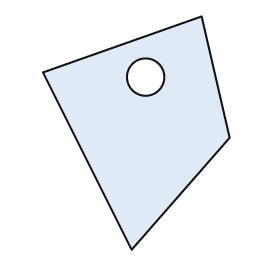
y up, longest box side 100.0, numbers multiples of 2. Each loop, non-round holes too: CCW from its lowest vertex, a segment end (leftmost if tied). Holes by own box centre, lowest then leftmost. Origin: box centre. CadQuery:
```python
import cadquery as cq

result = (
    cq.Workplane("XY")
    .moveTo(-2.0, -50.0)
    .lineTo(40.0, -2.0)
    .lineTo(28.0, 50.0)
    .lineTo(-40.0, 26.0)
    .close()
    .moveTo(4.0, 24.0)
    .circle(8.0)
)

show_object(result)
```